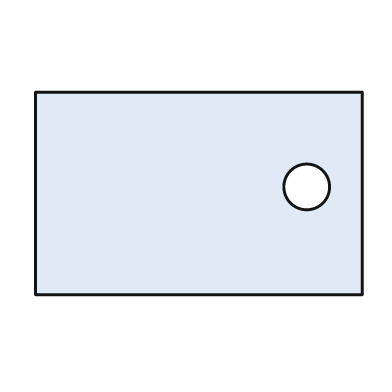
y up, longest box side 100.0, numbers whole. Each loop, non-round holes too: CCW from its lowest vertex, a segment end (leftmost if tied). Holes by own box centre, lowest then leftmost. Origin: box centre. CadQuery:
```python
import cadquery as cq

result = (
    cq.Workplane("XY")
    .moveTo(-50.0, -31.0)
    .lineTo(50.0, -31.0)
    .lineTo(50.0, 31.0)
    .lineTo(-50.0, 31.0)
    .close()
    .moveTo(33.0, 2.0)
    .circle(7.0)
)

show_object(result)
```